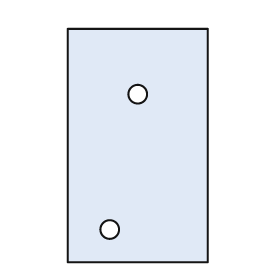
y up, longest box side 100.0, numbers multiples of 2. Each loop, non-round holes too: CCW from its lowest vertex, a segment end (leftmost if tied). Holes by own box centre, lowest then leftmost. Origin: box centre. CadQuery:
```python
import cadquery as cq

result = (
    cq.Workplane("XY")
    .moveTo(-30.0, -50.0)
    .lineTo(30.0, -50.0)
    .lineTo(30.0, 50.0)
    .lineTo(-30.0, 50.0)
    .close()
    .moveTo(-12.0, -36.0)
    .circle(4.0)
    .moveTo(0.0, 22.0)
    .circle(4.0)
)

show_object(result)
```